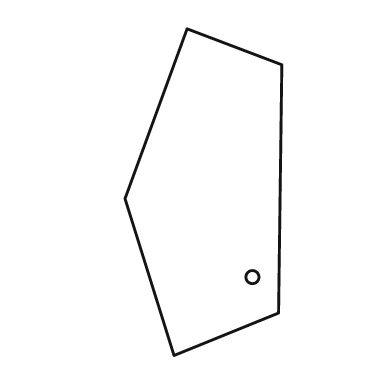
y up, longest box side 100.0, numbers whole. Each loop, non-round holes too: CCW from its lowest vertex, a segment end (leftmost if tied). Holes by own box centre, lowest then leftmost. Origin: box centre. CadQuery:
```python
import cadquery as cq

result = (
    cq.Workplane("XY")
    .moveTo(-9.0, -50.0)
    .lineTo(23.0, -37.0)
    .lineTo(24.0, 39.0)
    .lineTo(-5.0, 50.0)
    .lineTo(-24.0, -2.0)
    .close()
    .moveTo(15.0, -26.0)
    .circle(2.0)
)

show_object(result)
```